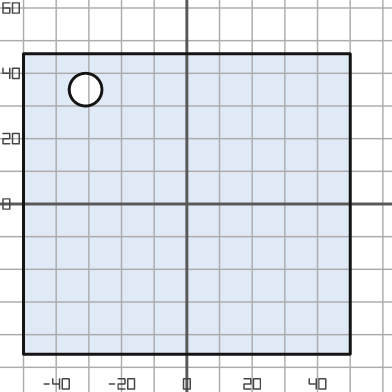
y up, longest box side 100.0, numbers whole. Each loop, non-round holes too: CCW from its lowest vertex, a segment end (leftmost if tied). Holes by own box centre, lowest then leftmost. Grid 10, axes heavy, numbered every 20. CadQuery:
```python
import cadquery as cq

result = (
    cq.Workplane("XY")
    .moveTo(-50.0, -46.0)
    .lineTo(50.0, -46.0)
    .lineTo(50.0, 46.0)
    .lineTo(-50.0, 46.0)
    .close()
    .moveTo(-31.0, 35.0)
    .circle(5.0)
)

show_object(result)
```